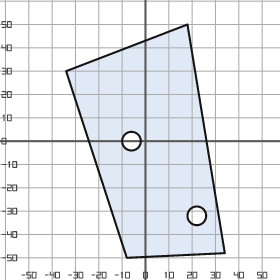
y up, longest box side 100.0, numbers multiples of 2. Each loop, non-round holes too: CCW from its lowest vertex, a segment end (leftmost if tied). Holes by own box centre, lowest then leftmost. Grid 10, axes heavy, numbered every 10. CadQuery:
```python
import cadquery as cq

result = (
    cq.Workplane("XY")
    .moveTo(-8.0, -50.0)
    .lineTo(34.0, -48.0)
    .lineTo(18.0, 50.0)
    .lineTo(-34.0, 30.0)
    .close()
    .moveTo(22.0, -32.0)
    .circle(4.0)
    .moveTo(-6.0, 0.0)
    .circle(4.0)
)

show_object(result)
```